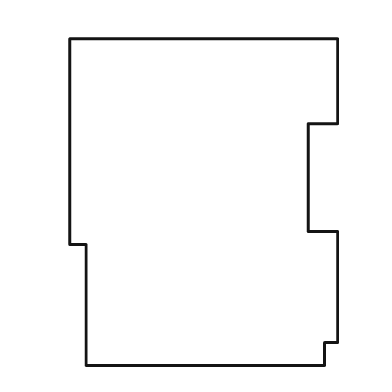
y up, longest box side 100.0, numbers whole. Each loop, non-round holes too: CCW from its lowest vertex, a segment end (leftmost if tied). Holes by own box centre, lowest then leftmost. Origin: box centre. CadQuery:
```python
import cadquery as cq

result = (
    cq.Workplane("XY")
    .moveTo(-36.0, -50.0)
    .lineTo(37.0, -50.0)
    .lineTo(37.0, -43.0)
    .lineTo(41.0, -43.0)
    .lineTo(41.0, -9.0)
    .lineTo(32.0, -9.0)
    .lineTo(32.0, 24.0)
    .lineTo(41.0, 24.0)
    .lineTo(41.0, 50.0)
    .lineTo(-41.0, 50.0)
    .lineTo(-41.0, -13.0)
    .lineTo(-36.0, -13.0)
    .close()
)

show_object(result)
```